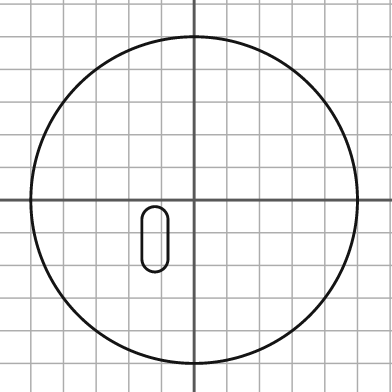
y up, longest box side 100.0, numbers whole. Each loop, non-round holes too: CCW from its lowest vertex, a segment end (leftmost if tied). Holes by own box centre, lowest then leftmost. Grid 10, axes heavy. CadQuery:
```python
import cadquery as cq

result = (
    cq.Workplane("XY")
    .moveTo(0.0, 0.0)
    .circle(50.0)
    .moveTo(-16.0, -18.0)
    .threePointArc((-12.0, -22.0), (-8.0, -18.0))
    .lineTo(-8.0, -6.0)
    .threePointArc((-12.0, -2.0), (-16.0, -6.0))
    .close()
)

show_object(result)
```